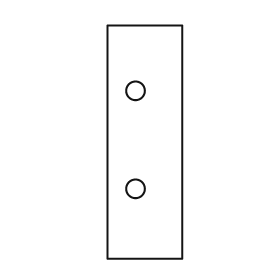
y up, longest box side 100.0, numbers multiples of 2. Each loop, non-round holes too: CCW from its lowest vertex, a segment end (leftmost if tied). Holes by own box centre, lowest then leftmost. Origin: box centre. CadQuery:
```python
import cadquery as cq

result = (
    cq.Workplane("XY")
    .moveTo(-16.0, -50.0)
    .lineTo(16.0, -50.0)
    .lineTo(16.0, 50.0)
    .lineTo(-16.0, 50.0)
    .close()
    .moveTo(-4.0, -20.0)
    .circle(4.0)
    .moveTo(-4.0, 22.0)
    .circle(4.0)
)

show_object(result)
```